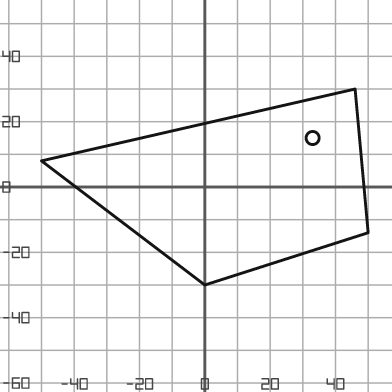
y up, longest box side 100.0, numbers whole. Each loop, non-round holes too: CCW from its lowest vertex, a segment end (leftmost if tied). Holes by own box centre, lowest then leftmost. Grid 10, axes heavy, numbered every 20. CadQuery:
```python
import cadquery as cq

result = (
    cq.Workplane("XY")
    .moveTo(0.0, -30.0)
    .lineTo(50.0, -14.0)
    .lineTo(46.0, 30.0)
    .lineTo(-50.0, 8.0)
    .close()
    .moveTo(33.0, 15.0)
    .circle(2.0)
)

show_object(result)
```